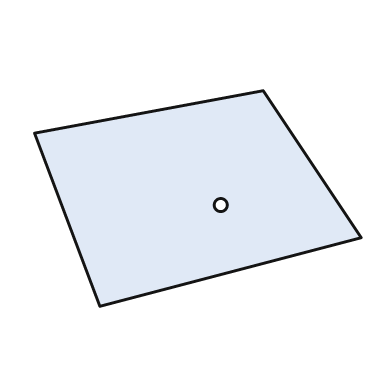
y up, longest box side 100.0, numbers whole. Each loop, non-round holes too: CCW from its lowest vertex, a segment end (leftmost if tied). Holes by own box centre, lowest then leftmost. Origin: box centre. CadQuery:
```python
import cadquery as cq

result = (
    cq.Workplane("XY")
    .moveTo(-30.0, -33.0)
    .lineTo(50.0, -12.0)
    .lineTo(20.0, 33.0)
    .lineTo(-50.0, 20.0)
    .close()
    .moveTo(7.0, -2.0)
    .circle(2.0)
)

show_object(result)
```